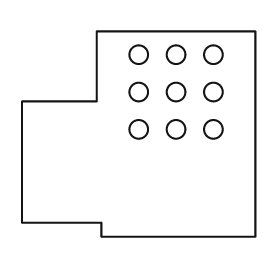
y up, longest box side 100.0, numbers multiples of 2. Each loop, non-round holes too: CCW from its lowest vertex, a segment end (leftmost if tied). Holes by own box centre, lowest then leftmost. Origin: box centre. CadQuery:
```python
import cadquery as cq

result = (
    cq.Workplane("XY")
    .moveTo(-16.0, -44.0)
    .lineTo(50.0, -44.0)
    .lineTo(50.0, 44.0)
    .lineTo(-18.0, 44.0)
    .lineTo(-18.0, 14.0)
    .lineTo(-50.0, 14.0)
    .lineTo(-50.0, -38.0)
    .lineTo(-16.0, -38.0)
    .close()
    .moveTo(0.0, 2.0)
    .circle(4.0)
    .moveTo(16.0, 2.0)
    .circle(4.0)
    .moveTo(32.0, 2.0)
    .circle(4.0)
    .moveTo(0.0, 18.0)
    .circle(4.0)
    .moveTo(16.0, 18.0)
    .circle(4.0)
    .moveTo(32.0, 18.0)
    .circle(4.0)
    .moveTo(0.0, 34.0)
    .circle(4.0)
    .moveTo(16.0, 34.0)
    .circle(4.0)
    .moveTo(32.0, 34.0)
    .circle(4.0)
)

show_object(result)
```